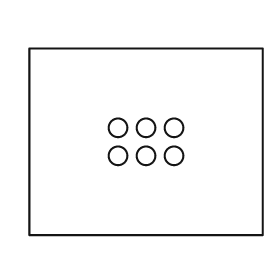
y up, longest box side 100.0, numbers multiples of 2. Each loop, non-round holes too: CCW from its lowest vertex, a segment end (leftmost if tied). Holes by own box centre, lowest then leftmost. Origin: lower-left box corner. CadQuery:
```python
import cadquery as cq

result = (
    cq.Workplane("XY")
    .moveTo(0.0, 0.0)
    .lineTo(100.0, 0.0)
    .lineTo(100.0, 80.0)
    .lineTo(0.0, 80.0)
    .close()
    .moveTo(38.0, 34.0)
    .circle(4.0)
    .moveTo(50.0, 34.0)
    .circle(4.0)
    .moveTo(62.0, 34.0)
    .circle(4.0)
    .moveTo(38.0, 46.0)
    .circle(4.0)
    .moveTo(50.0, 46.0)
    .circle(4.0)
    .moveTo(62.0, 46.0)
    .circle(4.0)
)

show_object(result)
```